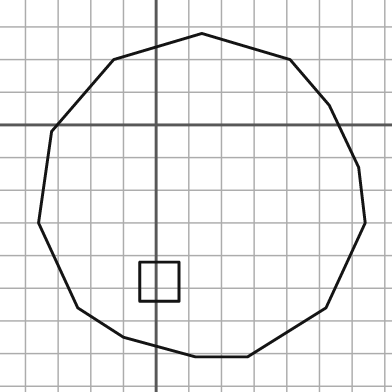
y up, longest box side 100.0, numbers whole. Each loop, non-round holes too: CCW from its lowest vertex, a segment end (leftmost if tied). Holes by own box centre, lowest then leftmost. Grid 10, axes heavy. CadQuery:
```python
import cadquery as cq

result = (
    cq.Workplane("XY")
    .moveTo(12.0, -71.0)
    .lineTo(28.0, -71.0)
    .lineTo(52.0, -56.0)
    .lineTo(64.0, -30.0)
    .lineTo(62.0, -13.0)
    .lineTo(53.0, 6.0)
    .lineTo(41.0, 20.0)
    .lineTo(14.0, 28.0)
    .lineTo(-13.0, 20.0)
    .lineTo(-32.0, -2.0)
    .lineTo(-36.0, -30.0)
    .lineTo(-24.0, -56.0)
    .lineTo(-10.0, -65.0)
    .close()
    .moveTo(-5.0, -54.0)
    .lineTo(7.0, -54.0)
    .lineTo(7.0, -42.0)
    .lineTo(-5.0, -42.0)
    .close()
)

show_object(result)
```